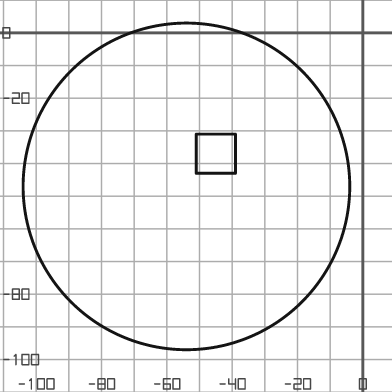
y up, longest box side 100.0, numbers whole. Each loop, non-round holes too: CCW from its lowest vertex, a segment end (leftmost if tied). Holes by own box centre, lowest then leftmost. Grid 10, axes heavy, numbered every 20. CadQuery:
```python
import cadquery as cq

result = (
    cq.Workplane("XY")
    .moveTo(-54.0, -47.0)
    .circle(50.0)
    .moveTo(-51.0, -43.0)
    .lineTo(-39.0, -43.0)
    .lineTo(-39.0, -31.0)
    .lineTo(-51.0, -31.0)
    .close()
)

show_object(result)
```